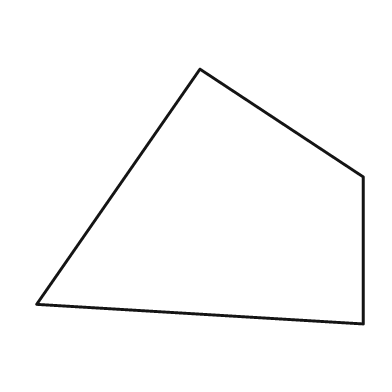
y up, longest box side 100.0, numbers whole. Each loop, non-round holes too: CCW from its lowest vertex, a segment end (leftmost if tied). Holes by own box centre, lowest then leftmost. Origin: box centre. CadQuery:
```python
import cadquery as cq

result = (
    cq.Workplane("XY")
    .moveTo(50.0, -39.0)
    .lineTo(50.0, 6.0)
    .lineTo(0.0, 39.0)
    .lineTo(-50.0, -33.0)
    .close()
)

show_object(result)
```